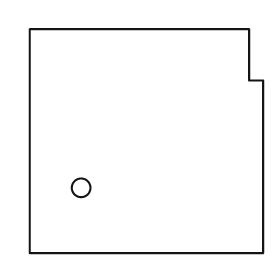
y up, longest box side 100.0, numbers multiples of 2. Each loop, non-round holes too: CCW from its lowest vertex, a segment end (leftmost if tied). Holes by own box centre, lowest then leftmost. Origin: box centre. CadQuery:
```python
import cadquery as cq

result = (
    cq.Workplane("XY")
    .moveTo(-50.0, -48.0)
    .lineTo(50.0, -48.0)
    .lineTo(50.0, 26.0)
    .lineTo(44.0, 26.0)
    .lineTo(44.0, 48.0)
    .lineTo(-50.0, 48.0)
    .close()
    .moveTo(-28.0, -20.0)
    .circle(4.0)
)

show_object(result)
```